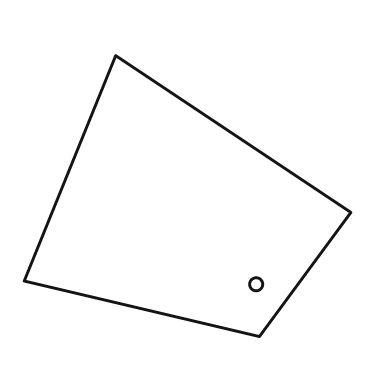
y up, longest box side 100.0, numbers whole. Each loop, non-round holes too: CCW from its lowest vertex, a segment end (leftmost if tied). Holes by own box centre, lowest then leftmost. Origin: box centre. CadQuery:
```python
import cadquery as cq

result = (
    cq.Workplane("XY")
    .moveTo(22.0, -43.0)
    .lineTo(50.0, -5.0)
    .lineTo(-22.0, 43.0)
    .lineTo(-50.0, -26.0)
    .close()
    .moveTo(21.0, -27.0)
    .circle(2.0)
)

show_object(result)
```